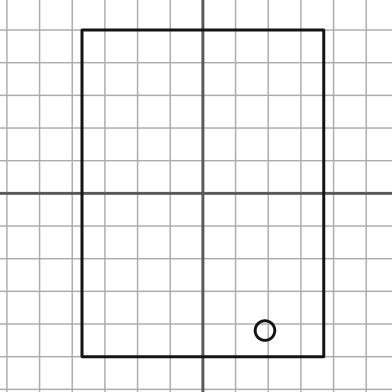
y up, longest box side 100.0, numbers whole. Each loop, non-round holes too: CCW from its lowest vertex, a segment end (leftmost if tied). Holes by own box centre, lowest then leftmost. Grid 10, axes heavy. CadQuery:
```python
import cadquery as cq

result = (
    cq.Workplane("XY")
    .moveTo(-37.0, -50.0)
    .lineTo(37.0, -50.0)
    .lineTo(37.0, 50.0)
    .lineTo(-37.0, 50.0)
    .close()
    .moveTo(19.0, -42.0)
    .circle(3.0)
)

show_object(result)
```